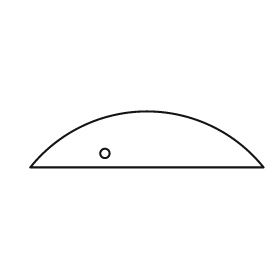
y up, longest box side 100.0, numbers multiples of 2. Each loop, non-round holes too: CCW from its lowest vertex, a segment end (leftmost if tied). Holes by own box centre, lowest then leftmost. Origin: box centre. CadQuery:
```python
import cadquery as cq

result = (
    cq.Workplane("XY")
    .moveTo(-50.0, -12.0)
    .lineTo(50.0, -12.0)
    .threePointArc((0.0, 12.0), (-50.0, -12.0))
    .close()
    .moveTo(-18.0, -6.0)
    .circle(2.0)
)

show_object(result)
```